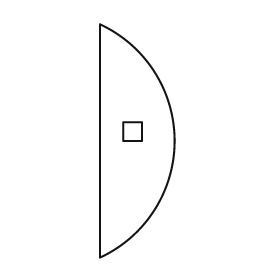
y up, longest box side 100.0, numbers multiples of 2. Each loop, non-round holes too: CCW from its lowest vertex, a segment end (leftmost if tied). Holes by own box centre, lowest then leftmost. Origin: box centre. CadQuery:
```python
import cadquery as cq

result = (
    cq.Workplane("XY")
    .moveTo(-16.0, -50.0)
    .threePointArc((16.0, 0.0), (-16.0, 50.0))
    .close()
    .moveTo(-6.0, 0.0)
    .lineTo(2.0, 0.0)
    .lineTo(2.0, 8.0)
    .lineTo(-6.0, 8.0)
    .close()
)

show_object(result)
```